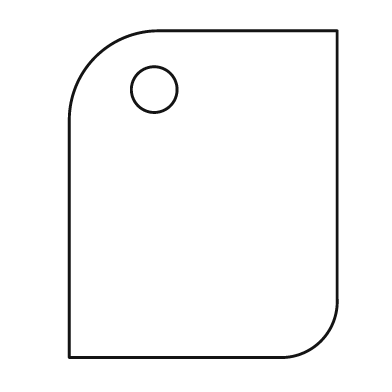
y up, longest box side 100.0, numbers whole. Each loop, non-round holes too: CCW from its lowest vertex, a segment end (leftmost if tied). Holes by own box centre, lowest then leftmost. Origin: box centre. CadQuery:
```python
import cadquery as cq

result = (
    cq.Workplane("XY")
    .moveTo(-41.0, -50.0)
    .lineTo(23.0, -50.0)
    .threePointArc((36.0, -45.0), (41.0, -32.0))
    .lineTo(41.0, 50.0)
    .lineTo(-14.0, 50.0)
    .threePointArc((-33.0, 42.0), (-41.0, 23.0))
    .close()
    .moveTo(-15.0, 32.0)
    .circle(7.0)
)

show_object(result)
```